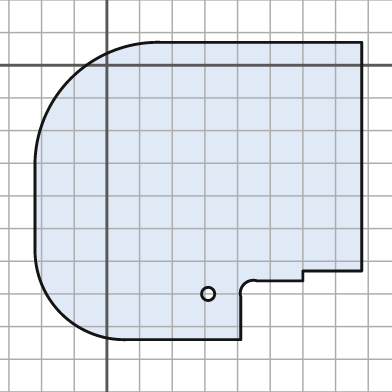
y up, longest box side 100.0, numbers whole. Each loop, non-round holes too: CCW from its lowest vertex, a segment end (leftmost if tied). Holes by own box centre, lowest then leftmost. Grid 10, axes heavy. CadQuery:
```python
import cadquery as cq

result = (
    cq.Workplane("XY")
    .moveTo(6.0, -84.0)
    .lineTo(41.0, -84.0)
    .lineTo(41.0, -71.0)
    .threePointArc((42.0, -67.0), (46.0, -66.0))
    .lineTo(60.0, -66.0)
    .lineTo(60.0, -63.0)
    .lineTo(78.0, -63.0)
    .lineTo(78.0, 7.0)
    .lineTo(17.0, 7.0)
    .threePointArc((-11.0, -4.0), (-22.0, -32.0))
    .lineTo(-22.0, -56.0)
    .threePointArc((-14.0, -76.0), (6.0, -84.0))
    .close()
    .moveTo(31.0, -70.0)
    .circle(2.0)
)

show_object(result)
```